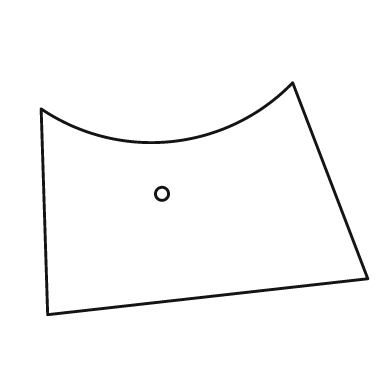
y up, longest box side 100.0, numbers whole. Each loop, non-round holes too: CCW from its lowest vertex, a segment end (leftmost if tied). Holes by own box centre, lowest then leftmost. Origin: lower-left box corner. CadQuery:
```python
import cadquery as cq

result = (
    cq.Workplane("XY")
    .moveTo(2.0, 0.0)
    .lineTo(100.0, 11.0)
    .lineTo(77.0, 71.0)
    .threePointArc((40.0, 53.0), (0.0, 63.0))
    .close()
    .moveTo(37.0, 37.0)
    .circle(2.0)
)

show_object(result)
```